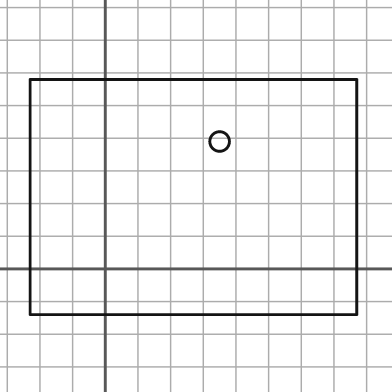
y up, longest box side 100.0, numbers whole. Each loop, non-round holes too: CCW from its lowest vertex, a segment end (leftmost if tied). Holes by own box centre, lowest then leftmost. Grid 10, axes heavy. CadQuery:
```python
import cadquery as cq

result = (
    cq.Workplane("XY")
    .moveTo(-23.0, -14.0)
    .lineTo(77.0, -14.0)
    .lineTo(77.0, 58.0)
    .lineTo(-23.0, 58.0)
    .close()
    .moveTo(35.0, 39.0)
    .circle(3.0)
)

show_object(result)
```